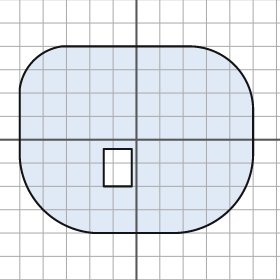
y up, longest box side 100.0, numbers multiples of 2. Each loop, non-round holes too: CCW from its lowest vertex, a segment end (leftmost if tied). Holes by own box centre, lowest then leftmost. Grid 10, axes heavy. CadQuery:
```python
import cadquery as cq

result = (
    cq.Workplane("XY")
    .moveTo(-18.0, -40.0)
    .lineTo(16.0, -40.0)
    .threePointArc((40.0, -30.0), (50.0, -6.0))
    .lineTo(50.0, 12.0)
    .threePointArc((42.0, 32.0), (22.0, 40.0))
    .lineTo(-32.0, 40.0)
    .threePointArc((-44.0, 34.0), (-50.0, 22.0))
    .lineTo(-50.0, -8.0)
    .threePointArc((-40.0, -30.0), (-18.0, -40.0))
    .close()
    .moveTo(-14.0, -20.0)
    .lineTo(-2.0, -20.0)
    .lineTo(-2.0, -4.0)
    .lineTo(-14.0, -4.0)
    .close()
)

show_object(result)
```